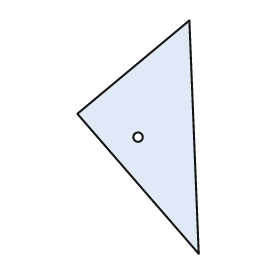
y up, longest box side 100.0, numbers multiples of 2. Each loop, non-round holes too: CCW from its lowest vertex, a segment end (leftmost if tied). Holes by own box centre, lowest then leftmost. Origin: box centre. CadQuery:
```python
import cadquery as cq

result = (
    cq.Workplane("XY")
    .moveTo(26.0, -50.0)
    .lineTo(22.0, 50.0)
    .lineTo(-26.0, 10.0)
    .close()
    .moveTo(0.0, 0.0)
    .circle(2.0)
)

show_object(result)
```